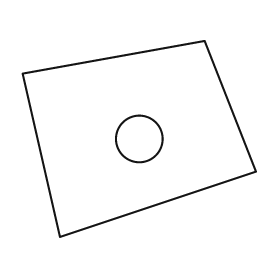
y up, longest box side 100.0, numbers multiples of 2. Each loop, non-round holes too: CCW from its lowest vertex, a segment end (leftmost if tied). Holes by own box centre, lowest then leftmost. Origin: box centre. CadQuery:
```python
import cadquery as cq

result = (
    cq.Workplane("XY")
    .moveTo(-34.0, -42.0)
    .lineTo(50.0, -14.0)
    .lineTo(28.0, 42.0)
    .lineTo(-50.0, 28.0)
    .close()
    .moveTo(0.0, 0.0)
    .circle(10.0)
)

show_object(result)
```